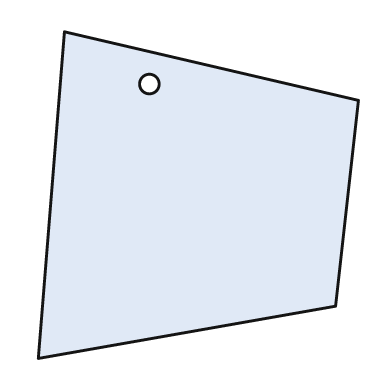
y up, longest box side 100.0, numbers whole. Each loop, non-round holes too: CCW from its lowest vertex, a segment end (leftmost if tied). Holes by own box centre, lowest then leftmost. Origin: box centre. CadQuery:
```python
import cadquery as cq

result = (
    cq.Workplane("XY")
    .moveTo(-49.0, -50.0)
    .lineTo(42.0, -34.0)
    .lineTo(49.0, 29.0)
    .lineTo(-41.0, 50.0)
    .close()
    .moveTo(-15.0, 34.0)
    .circle(3.0)
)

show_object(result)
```